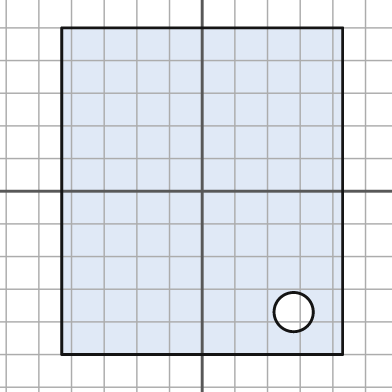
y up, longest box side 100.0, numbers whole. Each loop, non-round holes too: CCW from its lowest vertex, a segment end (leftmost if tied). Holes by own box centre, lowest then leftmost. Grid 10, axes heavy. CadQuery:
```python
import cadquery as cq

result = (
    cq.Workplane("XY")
    .moveTo(-43.0, -50.0)
    .lineTo(43.0, -50.0)
    .lineTo(43.0, 50.0)
    .lineTo(-43.0, 50.0)
    .close()
    .moveTo(28.0, -37.0)
    .circle(6.0)
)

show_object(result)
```